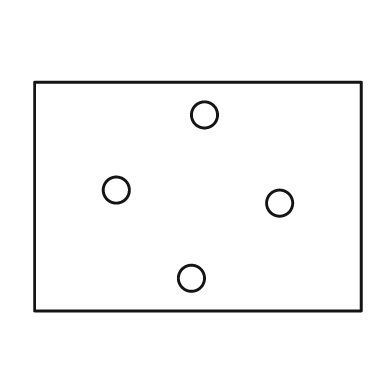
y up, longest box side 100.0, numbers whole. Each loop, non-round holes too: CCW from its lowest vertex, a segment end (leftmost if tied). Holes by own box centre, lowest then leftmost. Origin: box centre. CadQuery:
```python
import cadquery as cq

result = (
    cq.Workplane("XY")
    .moveTo(-50.0, -35.0)
    .lineTo(50.0, -35.0)
    .lineTo(50.0, 35.0)
    .lineTo(-50.0, 35.0)
    .close()
    .moveTo(-2.0, -25.0)
    .circle(4.0)
    .moveTo(25.0, -2.0)
    .circle(4.0)
    .moveTo(-25.0, 2.0)
    .circle(4.0)
    .moveTo(2.0, 25.0)
    .circle(4.0)
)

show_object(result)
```